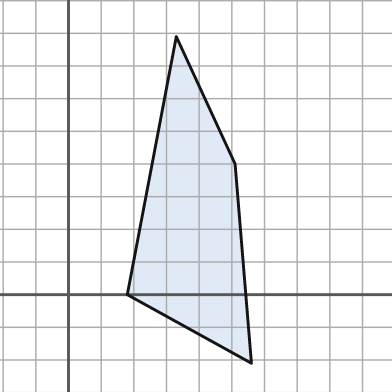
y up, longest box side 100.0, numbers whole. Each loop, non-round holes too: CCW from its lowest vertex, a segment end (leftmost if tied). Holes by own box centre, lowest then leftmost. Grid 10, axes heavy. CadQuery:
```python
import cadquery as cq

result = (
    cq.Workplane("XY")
    .moveTo(56.0, -21.0)
    .lineTo(51.0, 40.0)
    .lineTo(33.0, 79.0)
    .lineTo(18.0, 0.0)
    .close()
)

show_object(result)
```